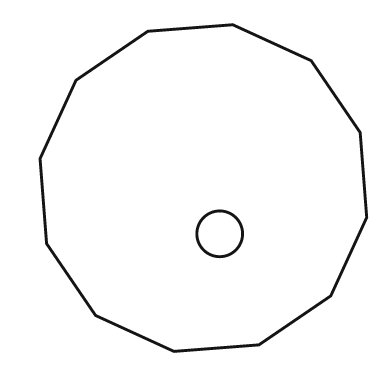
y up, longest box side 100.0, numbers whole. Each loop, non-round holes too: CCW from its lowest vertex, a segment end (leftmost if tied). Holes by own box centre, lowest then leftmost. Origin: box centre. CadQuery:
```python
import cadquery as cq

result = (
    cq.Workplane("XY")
    .moveTo(-9.0, -50.0)
    .lineTo(17.0, -48.0)
    .lineTo(39.0, -33.0)
    .lineTo(50.0, -9.0)
    .lineTo(48.0, 17.0)
    .lineTo(33.0, 39.0)
    .lineTo(9.0, 50.0)
    .lineTo(-17.0, 48.0)
    .lineTo(-39.0, 33.0)
    .lineTo(-50.0, 9.0)
    .lineTo(-48.0, -17.0)
    .lineTo(-33.0, -39.0)
    .close()
    .moveTo(5.0, -14.0)
    .circle(7.0)
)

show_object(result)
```